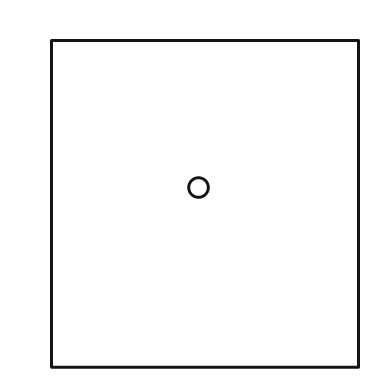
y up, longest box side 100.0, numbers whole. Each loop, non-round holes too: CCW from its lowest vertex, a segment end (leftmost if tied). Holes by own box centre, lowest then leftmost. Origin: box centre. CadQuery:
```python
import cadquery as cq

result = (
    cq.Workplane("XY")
    .moveTo(-47.0, -50.0)
    .lineTo(47.0, -50.0)
    .lineTo(47.0, 50.0)
    .lineTo(-47.0, 50.0)
    .close()
    .moveTo(-2.0, 5.0)
    .circle(3.0)
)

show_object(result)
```